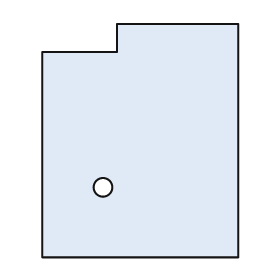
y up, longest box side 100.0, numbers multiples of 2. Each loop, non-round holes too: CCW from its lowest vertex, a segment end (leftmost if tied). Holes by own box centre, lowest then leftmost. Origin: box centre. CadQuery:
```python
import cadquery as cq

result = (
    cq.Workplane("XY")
    .moveTo(-42.0, -50.0)
    .lineTo(42.0, -50.0)
    .lineTo(42.0, 50.0)
    .lineTo(-10.0, 50.0)
    .lineTo(-10.0, 38.0)
    .lineTo(-42.0, 38.0)
    .close()
    .moveTo(-16.0, -20.0)
    .circle(4.0)
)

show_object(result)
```